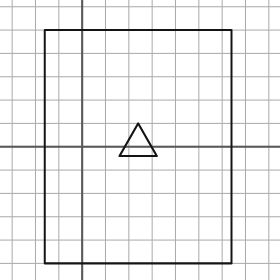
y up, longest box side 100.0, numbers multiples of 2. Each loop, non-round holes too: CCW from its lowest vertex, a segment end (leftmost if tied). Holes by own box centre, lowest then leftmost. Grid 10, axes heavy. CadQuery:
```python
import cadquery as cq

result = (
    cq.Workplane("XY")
    .moveTo(-16.0, -50.0)
    .lineTo(64.0, -50.0)
    .lineTo(64.0, 50.0)
    .lineTo(-16.0, 50.0)
    .close()
    .moveTo(16.0, -4.0)
    .lineTo(32.0, -4.0)
    .lineTo(24.0, 10.0)
    .close()
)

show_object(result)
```